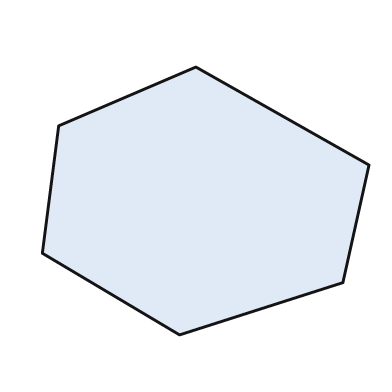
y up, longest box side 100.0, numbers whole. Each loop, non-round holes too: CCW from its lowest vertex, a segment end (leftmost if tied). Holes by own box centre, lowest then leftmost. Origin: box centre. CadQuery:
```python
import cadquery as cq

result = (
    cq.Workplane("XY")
    .moveTo(-8.0, -41.0)
    .lineTo(42.0, -25.0)
    .lineTo(50.0, 11.0)
    .lineTo(-3.0, 41.0)
    .lineTo(-45.0, 23.0)
    .lineTo(-50.0, -16.0)
    .close()
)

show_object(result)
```